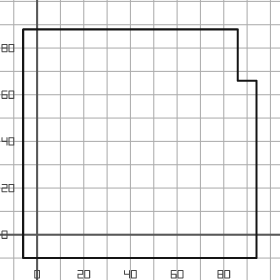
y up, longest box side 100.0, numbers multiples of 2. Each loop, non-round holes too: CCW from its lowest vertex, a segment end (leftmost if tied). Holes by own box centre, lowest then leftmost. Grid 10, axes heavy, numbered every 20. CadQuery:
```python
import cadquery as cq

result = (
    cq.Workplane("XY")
    .moveTo(-6.0, -10.0)
    .lineTo(94.0, -10.0)
    .lineTo(94.0, 66.0)
    .lineTo(86.0, 66.0)
    .lineTo(86.0, 88.0)
    .lineTo(-6.0, 88.0)
    .close()
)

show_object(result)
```